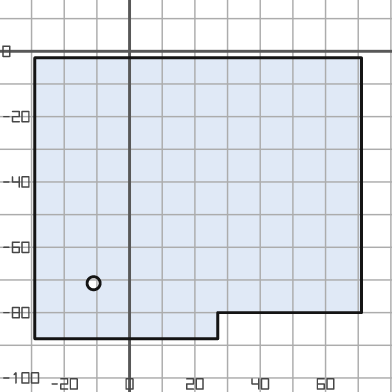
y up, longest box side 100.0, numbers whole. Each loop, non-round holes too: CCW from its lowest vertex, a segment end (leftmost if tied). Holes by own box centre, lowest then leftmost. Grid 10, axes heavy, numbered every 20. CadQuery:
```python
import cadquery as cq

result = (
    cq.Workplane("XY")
    .moveTo(-29.0, -88.0)
    .lineTo(27.0, -88.0)
    .lineTo(27.0, -80.0)
    .lineTo(71.0, -80.0)
    .lineTo(71.0, -2.0)
    .lineTo(-29.0, -2.0)
    .close()
    .moveTo(-11.0, -71.0)
    .circle(2.0)
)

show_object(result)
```